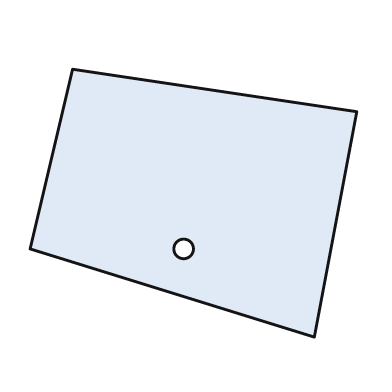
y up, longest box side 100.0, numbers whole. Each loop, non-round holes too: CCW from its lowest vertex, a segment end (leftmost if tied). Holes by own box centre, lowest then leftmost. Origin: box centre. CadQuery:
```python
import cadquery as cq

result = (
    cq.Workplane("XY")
    .moveTo(37.0, -41.0)
    .lineTo(50.0, 28.0)
    .lineTo(-37.0, 41.0)
    .lineTo(-50.0, -14.0)
    .close()
    .moveTo(-3.0, -14.0)
    .circle(3.0)
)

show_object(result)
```